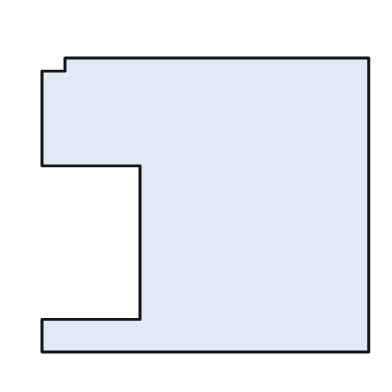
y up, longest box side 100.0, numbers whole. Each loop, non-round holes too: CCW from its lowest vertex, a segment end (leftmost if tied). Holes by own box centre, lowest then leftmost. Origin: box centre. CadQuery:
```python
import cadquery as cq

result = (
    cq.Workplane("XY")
    .moveTo(-50.0, -45.0)
    .lineTo(50.0, -45.0)
    .lineTo(50.0, 45.0)
    .lineTo(-43.0, 45.0)
    .lineTo(-43.0, 41.0)
    .lineTo(-50.0, 41.0)
    .lineTo(-50.0, 12.0)
    .lineTo(-20.0, 12.0)
    .lineTo(-20.0, -35.0)
    .lineTo(-50.0, -35.0)
    .close()
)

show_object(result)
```